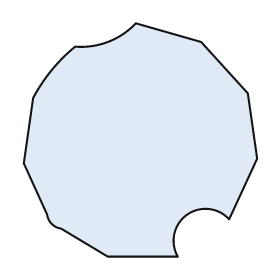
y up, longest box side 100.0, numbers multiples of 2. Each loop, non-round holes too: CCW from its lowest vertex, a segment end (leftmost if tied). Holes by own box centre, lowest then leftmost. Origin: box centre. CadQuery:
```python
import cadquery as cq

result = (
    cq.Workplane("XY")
    .moveTo(-14.0, -50.0)
    .lineTo(16.0, -50.0)
    .threePointArc((20.0, -32.0), (38.0, -34.0))
    .lineTo(50.0, -8.0)
    .lineTo(46.0, 20.0)
    .lineTo(26.0, 42.0)
    .lineTo(-2.0, 50.0)
    .threePointArc((-14.0, 42.0), (-28.0, 40.0))
    .threePointArc((-38.0, 30.0), (-46.0, 18.0))
    .lineTo(-50.0, -10.0)
    .lineTo(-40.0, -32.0)
    .threePointArc((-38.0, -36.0), (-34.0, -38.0))
    .close()
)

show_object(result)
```